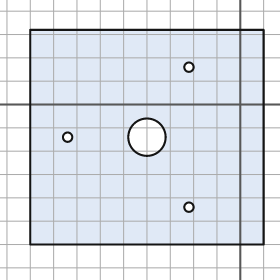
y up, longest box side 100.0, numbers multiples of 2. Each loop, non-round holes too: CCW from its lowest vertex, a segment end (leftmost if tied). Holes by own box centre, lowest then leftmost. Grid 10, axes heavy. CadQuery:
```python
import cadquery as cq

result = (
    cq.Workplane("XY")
    .moveTo(-90.0, -60.0)
    .lineTo(10.0, -60.0)
    .lineTo(10.0, 32.0)
    .lineTo(-90.0, 32.0)
    .close()
    .moveTo(-22.0, -44.0)
    .circle(2.0)
    .moveTo(-74.0, -14.0)
    .circle(2.0)
    .moveTo(-40.0, -14.0)
    .circle(8.0)
    .moveTo(-22.0, 16.0)
    .circle(2.0)
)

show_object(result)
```